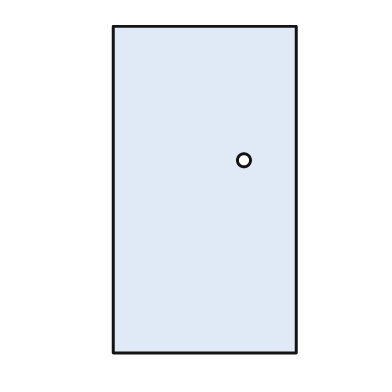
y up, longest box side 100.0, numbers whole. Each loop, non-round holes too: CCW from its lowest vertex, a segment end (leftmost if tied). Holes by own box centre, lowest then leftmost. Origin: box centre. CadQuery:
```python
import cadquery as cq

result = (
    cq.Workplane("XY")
    .moveTo(-28.0, -50.0)
    .lineTo(28.0, -50.0)
    .lineTo(28.0, 50.0)
    .lineTo(-28.0, 50.0)
    .close()
    .moveTo(12.0, 9.0)
    .circle(2.0)
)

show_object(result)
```